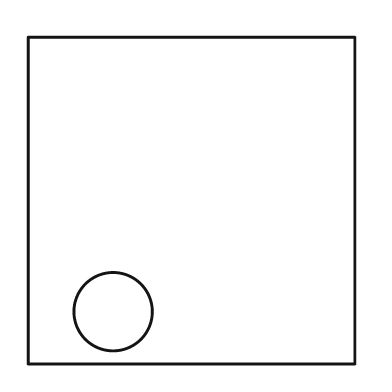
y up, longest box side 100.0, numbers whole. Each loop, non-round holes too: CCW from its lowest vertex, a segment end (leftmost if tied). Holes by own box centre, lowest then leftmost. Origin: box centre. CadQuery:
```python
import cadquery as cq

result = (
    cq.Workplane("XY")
    .moveTo(-50.0, -50.0)
    .lineTo(50.0, -50.0)
    .lineTo(50.0, 50.0)
    .lineTo(-50.0, 50.0)
    .close()
    .moveTo(-24.0, -34.0)
    .circle(12.0)
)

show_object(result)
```